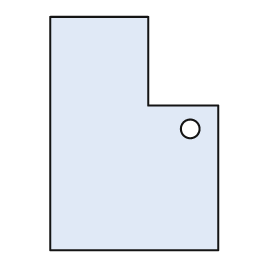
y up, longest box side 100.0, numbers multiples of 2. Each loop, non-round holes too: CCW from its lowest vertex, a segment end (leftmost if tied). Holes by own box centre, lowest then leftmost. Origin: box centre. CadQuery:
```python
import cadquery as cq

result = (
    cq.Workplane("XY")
    .moveTo(-36.0, -50.0)
    .lineTo(36.0, -50.0)
    .lineTo(36.0, 12.0)
    .lineTo(6.0, 12.0)
    .lineTo(6.0, 50.0)
    .lineTo(-36.0, 50.0)
    .close()
    .moveTo(24.0, 2.0)
    .circle(4.0)
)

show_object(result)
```